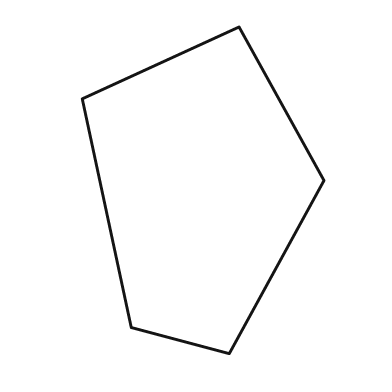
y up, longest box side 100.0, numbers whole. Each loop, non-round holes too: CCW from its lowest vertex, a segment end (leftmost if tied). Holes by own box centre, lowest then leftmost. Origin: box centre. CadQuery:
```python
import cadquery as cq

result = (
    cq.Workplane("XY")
    .moveTo(8.0, -50.0)
    .lineTo(37.0, 3.0)
    .lineTo(11.0, 50.0)
    .lineTo(-37.0, 28.0)
    .lineTo(-22.0, -42.0)
    .close()
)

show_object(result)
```